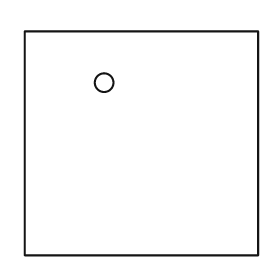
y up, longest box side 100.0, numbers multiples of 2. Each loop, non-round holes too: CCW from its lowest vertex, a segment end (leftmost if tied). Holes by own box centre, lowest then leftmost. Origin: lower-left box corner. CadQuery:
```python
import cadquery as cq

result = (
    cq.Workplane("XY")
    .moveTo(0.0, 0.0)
    .lineTo(100.0, 0.0)
    .lineTo(100.0, 96.0)
    .lineTo(0.0, 96.0)
    .close()
    .moveTo(34.0, 74.0)
    .circle(4.0)
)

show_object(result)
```